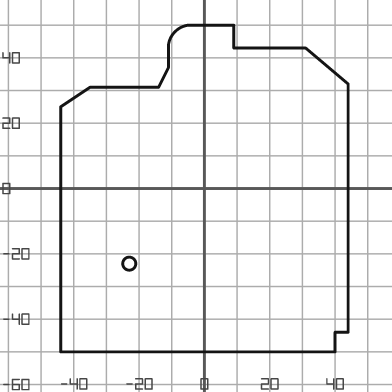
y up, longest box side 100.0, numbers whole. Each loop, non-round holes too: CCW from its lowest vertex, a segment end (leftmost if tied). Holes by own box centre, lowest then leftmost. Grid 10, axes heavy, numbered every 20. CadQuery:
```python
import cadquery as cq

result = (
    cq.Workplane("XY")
    .moveTo(-44.0, -50.0)
    .lineTo(40.0, -50.0)
    .lineTo(40.0, -44.0)
    .lineTo(44.0, -44.0)
    .lineTo(44.0, 32.0)
    .lineTo(31.0, 43.0)
    .lineTo(9.0, 43.0)
    .lineTo(9.0, 50.0)
    .lineTo(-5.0, 50.0)
    .threePointArc((-9.0, 48.0), (-11.0, 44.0))
    .lineTo(-11.0, 37.0)
    .lineTo(-14.0, 31.0)
    .lineTo(-35.0, 31.0)
    .lineTo(-44.0, 25.0)
    .close()
    .moveTo(-23.0, -23.0)
    .circle(2.0)
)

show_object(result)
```